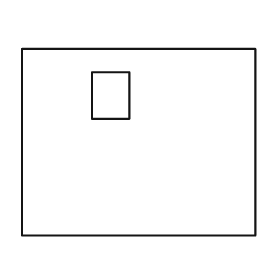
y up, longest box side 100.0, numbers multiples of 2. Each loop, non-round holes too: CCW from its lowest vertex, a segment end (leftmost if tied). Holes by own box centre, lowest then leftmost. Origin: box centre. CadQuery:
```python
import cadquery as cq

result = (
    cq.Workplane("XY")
    .moveTo(-50.0, -40.0)
    .lineTo(50.0, -40.0)
    .lineTo(50.0, 40.0)
    .lineTo(-50.0, 40.0)
    .close()
    .moveTo(-20.0, 10.0)
    .lineTo(-4.0, 10.0)
    .lineTo(-4.0, 30.0)
    .lineTo(-20.0, 30.0)
    .close()
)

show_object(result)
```